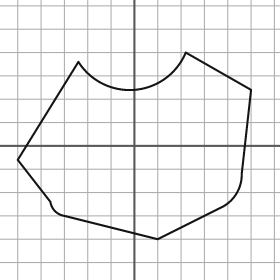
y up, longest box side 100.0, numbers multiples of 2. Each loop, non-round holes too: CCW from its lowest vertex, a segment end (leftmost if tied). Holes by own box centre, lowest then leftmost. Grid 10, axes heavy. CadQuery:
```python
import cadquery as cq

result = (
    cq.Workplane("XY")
    .moveTo(10.0, -40.0)
    .lineTo(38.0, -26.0)
    .threePointArc((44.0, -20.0), (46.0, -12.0))
    .lineTo(50.0, 24.0)
    .lineTo(22.0, 40.0)
    .threePointArc((0.0, 24.0), (-24.0, 36.0))
    .lineTo(-50.0, -6.0)
    .lineTo(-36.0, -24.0)
    .threePointArc((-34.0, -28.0), (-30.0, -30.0))
    .close()
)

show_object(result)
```